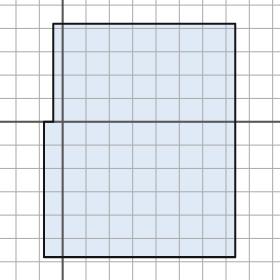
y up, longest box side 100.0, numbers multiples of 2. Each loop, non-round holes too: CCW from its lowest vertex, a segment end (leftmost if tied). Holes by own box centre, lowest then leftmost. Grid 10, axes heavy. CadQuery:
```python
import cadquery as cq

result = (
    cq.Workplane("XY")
    .moveTo(-8.0, -58.0)
    .lineTo(74.0, -58.0)
    .lineTo(74.0, 42.0)
    .lineTo(-4.0, 42.0)
    .lineTo(-4.0, 0.0)
    .lineTo(-8.0, 0.0)
    .close()
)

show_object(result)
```